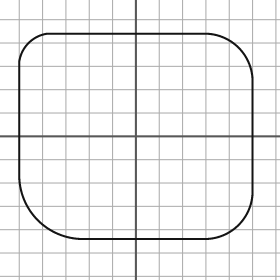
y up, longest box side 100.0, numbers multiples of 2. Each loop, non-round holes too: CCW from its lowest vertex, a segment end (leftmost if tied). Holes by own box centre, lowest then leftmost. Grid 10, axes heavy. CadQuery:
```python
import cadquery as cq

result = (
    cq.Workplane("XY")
    .moveTo(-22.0, -44.0)
    .lineTo(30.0, -44.0)
    .threePointArc((44.0, -38.0), (50.0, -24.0))
    .lineTo(50.0, 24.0)
    .threePointArc((44.0, 38.0), (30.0, 44.0))
    .lineTo(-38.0, 44.0)
    .threePointArc((-46.0, 40.0), (-50.0, 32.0))
    .lineTo(-50.0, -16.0)
    .threePointArc((-42.0, -36.0), (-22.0, -44.0))
    .close()
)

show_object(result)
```